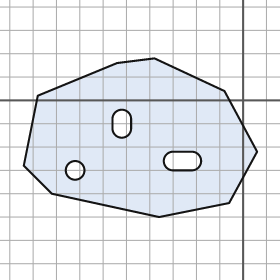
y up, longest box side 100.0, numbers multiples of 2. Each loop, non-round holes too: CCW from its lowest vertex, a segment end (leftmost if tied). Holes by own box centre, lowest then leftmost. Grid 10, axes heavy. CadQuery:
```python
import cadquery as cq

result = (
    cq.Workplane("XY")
    .moveTo(-36.0, -50.0)
    .lineTo(-6.0, -44.0)
    .lineTo(6.0, -22.0)
    .lineTo(-8.0, 4.0)
    .lineTo(-38.0, 18.0)
    .lineTo(-54.0, 16.0)
    .lineTo(-88.0, 2.0)
    .lineTo(-94.0, -28.0)
    .lineTo(-82.0, -40.0)
    .close()
    .moveTo(-72.0, -30.0)
    .circle(4.0)
    .moveTo(-30.0, -30.0)
    .lineTo(-22.0, -30.0)
    .threePointArc((-18.0, -26.0), (-22.0, -22.0))
    .lineTo(-30.0, -22.0)
    .threePointArc((-34.0, -26.0), (-30.0, -30.0))
    .close()
    .moveTo(-56.0, -12.0)
    .threePointArc((-52.0, -16.0), (-48.0, -12.0))
    .lineTo(-48.0, -8.0)
    .threePointArc((-52.0, -4.0), (-56.0, -8.0))
    .close()
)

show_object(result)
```